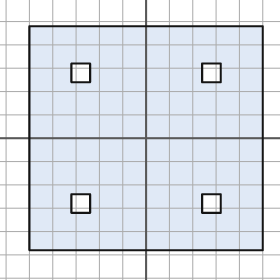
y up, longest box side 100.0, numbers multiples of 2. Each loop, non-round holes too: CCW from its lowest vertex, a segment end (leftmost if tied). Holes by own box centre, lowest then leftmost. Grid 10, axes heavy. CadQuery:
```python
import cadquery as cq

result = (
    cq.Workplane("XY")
    .moveTo(-50.0, -48.0)
    .lineTo(50.0, -48.0)
    .lineTo(50.0, 48.0)
    .lineTo(-50.0, 48.0)
    .close()
    .moveTo(-32.0, -32.0)
    .lineTo(-24.0, -32.0)
    .lineTo(-24.0, -24.0)
    .lineTo(-32.0, -24.0)
    .close()
    .moveTo(24.0, -32.0)
    .lineTo(32.0, -32.0)
    .lineTo(32.0, -24.0)
    .lineTo(24.0, -24.0)
    .close()
    .moveTo(-32.0, 24.0)
    .lineTo(-24.0, 24.0)
    .lineTo(-24.0, 32.0)
    .lineTo(-32.0, 32.0)
    .close()
    .moveTo(24.0, 24.0)
    .lineTo(32.0, 24.0)
    .lineTo(32.0, 32.0)
    .lineTo(24.0, 32.0)
    .close()
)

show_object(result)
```